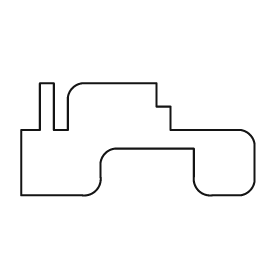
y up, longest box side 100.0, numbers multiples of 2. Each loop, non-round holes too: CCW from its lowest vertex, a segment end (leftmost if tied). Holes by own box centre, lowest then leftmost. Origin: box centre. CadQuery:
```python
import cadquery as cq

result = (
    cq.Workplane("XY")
    .moveTo(-50.0, -24.0)
    .lineTo(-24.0, -24.0)
    .threePointArc((-18.0, -22.0), (-16.0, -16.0))
    .lineTo(-16.0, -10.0)
    .threePointArc((-14.0, -6.0), (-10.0, -4.0))
    .lineTo(24.0, -4.0)
    .lineTo(24.0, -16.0)
    .threePointArc((26.0, -22.0), (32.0, -24.0))
    .lineTo(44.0, -24.0)
    .threePointArc((48.0, -22.0), (50.0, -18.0))
    .lineTo(50.0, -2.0)
    .threePointArc((48.0, 2.0), (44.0, 4.0))
    .lineTo(14.0, 4.0)
    .lineTo(14.0, 14.0)
    .lineTo(8.0, 14.0)
    .lineTo(8.0, 24.0)
    .lineTo(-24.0, 24.0)
    .threePointArc((-28.0, 22.0), (-30.0, 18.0))
    .lineTo(-30.0, 4.0)
    .lineTo(-36.0, 4.0)
    .lineTo(-36.0, 24.0)
    .lineTo(-42.0, 24.0)
    .lineTo(-42.0, 4.0)
    .lineTo(-50.0, 4.0)
    .close()
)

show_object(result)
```